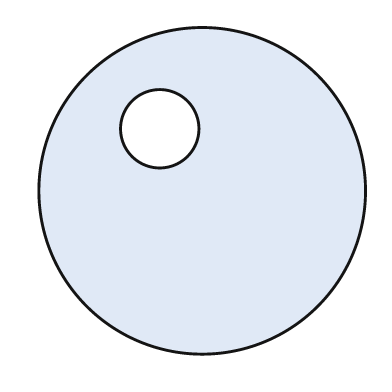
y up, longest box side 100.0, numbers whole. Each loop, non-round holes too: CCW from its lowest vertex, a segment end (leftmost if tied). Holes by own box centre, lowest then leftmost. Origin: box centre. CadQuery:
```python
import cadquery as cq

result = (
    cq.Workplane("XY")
    .moveTo(0.0, 0.0)
    .circle(50.0)
    .moveTo(-13.0, 19.0)
    .circle(12.0)
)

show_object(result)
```